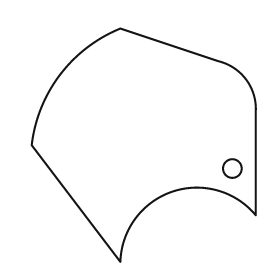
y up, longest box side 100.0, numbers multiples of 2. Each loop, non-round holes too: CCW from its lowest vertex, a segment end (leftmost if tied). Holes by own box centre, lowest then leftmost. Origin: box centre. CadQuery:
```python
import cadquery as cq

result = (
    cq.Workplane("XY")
    .moveTo(-10.0, -50.0)
    .threePointArc((12.0, -20.0), (48.0, -30.0))
    .lineTo(48.0, 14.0)
    .threePointArc((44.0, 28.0), (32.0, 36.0))
    .lineTo(-10.0, 50.0)
    .threePointArc((-36.0, 30.0), (-48.0, 0.0))
    .close()
    .moveTo(38.0, -10.0)
    .circle(4.0)
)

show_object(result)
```